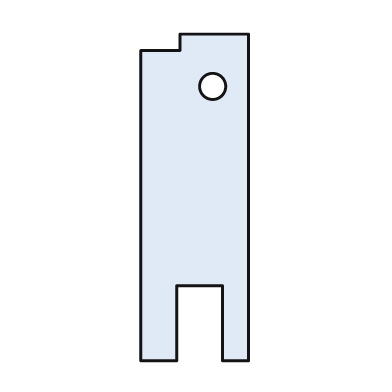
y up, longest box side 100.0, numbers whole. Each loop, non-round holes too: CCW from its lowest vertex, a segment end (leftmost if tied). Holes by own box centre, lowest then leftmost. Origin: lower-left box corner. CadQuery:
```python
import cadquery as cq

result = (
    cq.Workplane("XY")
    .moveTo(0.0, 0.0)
    .lineTo(11.0, 0.0)
    .lineTo(11.0, 23.0)
    .lineTo(25.0, 23.0)
    .lineTo(25.0, 0.0)
    .lineTo(33.0, 0.0)
    .lineTo(33.0, 100.0)
    .lineTo(12.0, 100.0)
    .lineTo(12.0, 95.0)
    .lineTo(0.0, 95.0)
    .close()
    .moveTo(22.0, 84.0)
    .circle(4.0)
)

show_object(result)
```